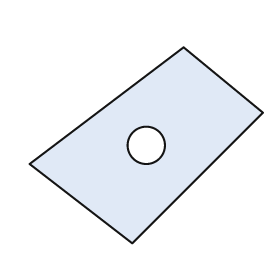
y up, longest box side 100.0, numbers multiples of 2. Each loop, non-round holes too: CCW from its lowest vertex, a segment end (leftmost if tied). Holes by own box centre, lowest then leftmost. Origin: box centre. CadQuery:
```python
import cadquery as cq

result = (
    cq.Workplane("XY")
    .moveTo(-6.0, -42.0)
    .lineTo(50.0, 14.0)
    .lineTo(16.0, 42.0)
    .lineTo(-50.0, -8.0)
    .close()
    .moveTo(0.0, 0.0)
    .circle(8.0)
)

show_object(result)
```